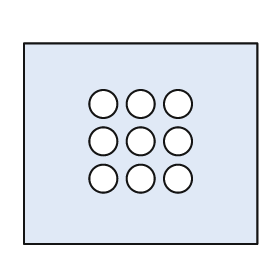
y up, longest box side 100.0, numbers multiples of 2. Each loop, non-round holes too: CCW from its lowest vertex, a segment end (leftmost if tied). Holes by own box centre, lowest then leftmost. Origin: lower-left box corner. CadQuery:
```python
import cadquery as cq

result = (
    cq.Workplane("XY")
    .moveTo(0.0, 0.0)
    .lineTo(100.0, 0.0)
    .lineTo(100.0, 86.0)
    .lineTo(0.0, 86.0)
    .close()
    .moveTo(34.0, 28.0)
    .circle(6.0)
    .moveTo(50.0, 28.0)
    .circle(6.0)
    .moveTo(66.0, 28.0)
    .circle(6.0)
    .moveTo(34.0, 44.0)
    .circle(6.0)
    .moveTo(50.0, 44.0)
    .circle(6.0)
    .moveTo(66.0, 44.0)
    .circle(6.0)
    .moveTo(34.0, 60.0)
    .circle(6.0)
    .moveTo(50.0, 60.0)
    .circle(6.0)
    .moveTo(66.0, 60.0)
    .circle(6.0)
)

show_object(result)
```